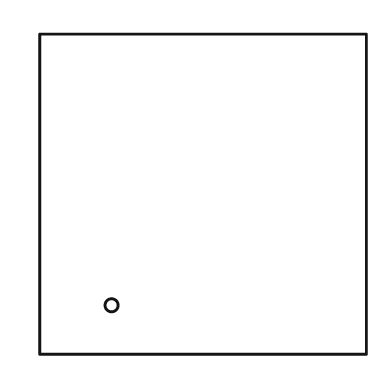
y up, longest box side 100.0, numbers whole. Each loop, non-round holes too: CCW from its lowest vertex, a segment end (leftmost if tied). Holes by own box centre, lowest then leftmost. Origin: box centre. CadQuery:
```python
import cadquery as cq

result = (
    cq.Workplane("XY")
    .moveTo(-50.0, -49.0)
    .lineTo(50.0, -49.0)
    .lineTo(50.0, 49.0)
    .lineTo(-50.0, 49.0)
    .close()
    .moveTo(-28.0, -34.0)
    .circle(2.0)
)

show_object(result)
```